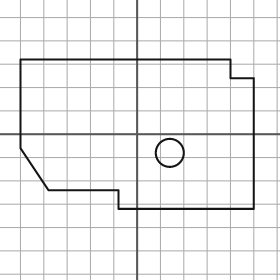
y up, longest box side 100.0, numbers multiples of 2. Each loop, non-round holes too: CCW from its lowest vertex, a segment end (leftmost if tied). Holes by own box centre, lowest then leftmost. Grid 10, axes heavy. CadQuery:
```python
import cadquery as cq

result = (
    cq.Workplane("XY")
    .moveTo(-8.0, -32.0)
    .lineTo(50.0, -32.0)
    .lineTo(50.0, 24.0)
    .lineTo(40.0, 24.0)
    .lineTo(40.0, 32.0)
    .lineTo(-50.0, 32.0)
    .lineTo(-50.0, -6.0)
    .lineTo(-38.0, -24.0)
    .lineTo(-8.0, -24.0)
    .close()
    .moveTo(14.0, -8.0)
    .circle(6.0)
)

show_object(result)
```